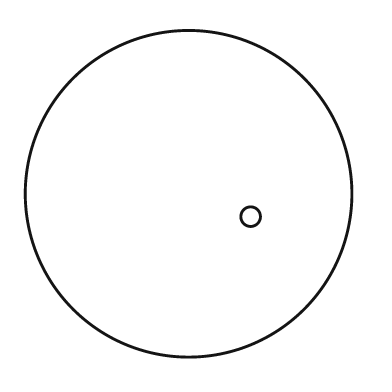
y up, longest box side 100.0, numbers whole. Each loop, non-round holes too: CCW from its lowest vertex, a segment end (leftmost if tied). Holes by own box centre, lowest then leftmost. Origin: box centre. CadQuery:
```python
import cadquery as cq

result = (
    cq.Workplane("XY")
    .moveTo(0.0, 0.0)
    .circle(50.0)
    .moveTo(19.0, -7.0)
    .circle(3.0)
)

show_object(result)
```